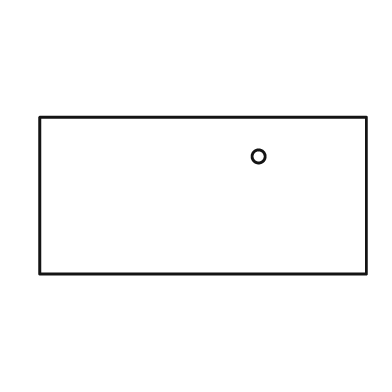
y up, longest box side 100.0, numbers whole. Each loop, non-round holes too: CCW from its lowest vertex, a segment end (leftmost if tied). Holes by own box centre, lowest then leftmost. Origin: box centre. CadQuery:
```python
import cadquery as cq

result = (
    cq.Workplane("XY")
    .moveTo(-50.0, -24.0)
    .lineTo(50.0, -24.0)
    .lineTo(50.0, 24.0)
    .lineTo(-50.0, 24.0)
    .close()
    .moveTo(17.0, 12.0)
    .circle(2.0)
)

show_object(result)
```